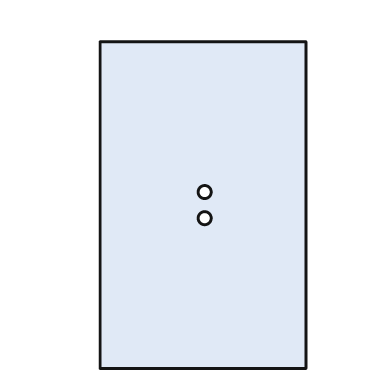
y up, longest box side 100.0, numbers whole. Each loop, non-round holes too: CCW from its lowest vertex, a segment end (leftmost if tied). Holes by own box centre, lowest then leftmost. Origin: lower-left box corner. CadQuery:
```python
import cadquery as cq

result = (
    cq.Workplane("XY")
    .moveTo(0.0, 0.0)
    .lineTo(63.0, 0.0)
    .lineTo(63.0, 100.0)
    .lineTo(0.0, 100.0)
    .close()
    .moveTo(32.0, 46.0)
    .circle(2.0)
    .moveTo(32.0, 54.0)
    .circle(2.0)
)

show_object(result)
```